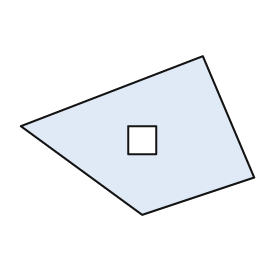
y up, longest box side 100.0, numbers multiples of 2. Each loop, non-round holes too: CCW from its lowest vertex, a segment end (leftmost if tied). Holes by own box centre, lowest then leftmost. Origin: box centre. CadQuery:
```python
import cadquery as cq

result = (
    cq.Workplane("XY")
    .moveTo(2.0, -34.0)
    .lineTo(50.0, -18.0)
    .lineTo(28.0, 34.0)
    .lineTo(-50.0, 4.0)
    .close()
    .moveTo(-4.0, -8.0)
    .lineTo(8.0, -8.0)
    .lineTo(8.0, 4.0)
    .lineTo(-4.0, 4.0)
    .close()
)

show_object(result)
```